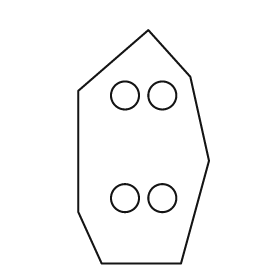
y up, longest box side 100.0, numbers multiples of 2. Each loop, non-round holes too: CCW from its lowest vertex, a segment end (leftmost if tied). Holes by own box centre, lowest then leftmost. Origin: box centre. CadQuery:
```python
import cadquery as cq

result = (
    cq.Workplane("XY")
    .moveTo(-18.0, -50.0)
    .lineTo(16.0, -50.0)
    .lineTo(28.0, -6.0)
    .lineTo(20.0, 30.0)
    .lineTo(2.0, 50.0)
    .lineTo(-28.0, 24.0)
    .lineTo(-28.0, -28.0)
    .close()
    .moveTo(-8.0, -22.0)
    .circle(6.0)
    .moveTo(8.0, -22.0)
    .circle(6.0)
    .moveTo(-8.0, 22.0)
    .circle(6.0)
    .moveTo(8.0, 22.0)
    .circle(6.0)
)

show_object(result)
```